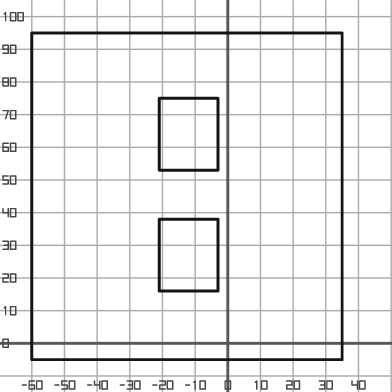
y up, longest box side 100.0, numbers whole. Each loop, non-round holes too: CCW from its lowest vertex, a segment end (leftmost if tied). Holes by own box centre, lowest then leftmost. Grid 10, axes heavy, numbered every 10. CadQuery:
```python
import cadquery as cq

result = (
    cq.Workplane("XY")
    .moveTo(-60.0, -5.0)
    .lineTo(35.0, -5.0)
    .lineTo(35.0, 95.0)
    .lineTo(-60.0, 95.0)
    .close()
    .moveTo(-21.0, 16.0)
    .lineTo(-3.0, 16.0)
    .lineTo(-3.0, 38.0)
    .lineTo(-21.0, 38.0)
    .close()
    .moveTo(-21.0, 53.0)
    .lineTo(-3.0, 53.0)
    .lineTo(-3.0, 75.0)
    .lineTo(-21.0, 75.0)
    .close()
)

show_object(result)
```